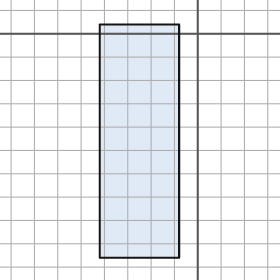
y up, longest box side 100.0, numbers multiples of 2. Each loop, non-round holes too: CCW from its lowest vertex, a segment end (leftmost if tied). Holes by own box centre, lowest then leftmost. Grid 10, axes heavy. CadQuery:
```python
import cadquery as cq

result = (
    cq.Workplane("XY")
    .moveTo(-42.0, -96.0)
    .lineTo(-8.0, -96.0)
    .lineTo(-8.0, 4.0)
    .lineTo(-42.0, 4.0)
    .close()
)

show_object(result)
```